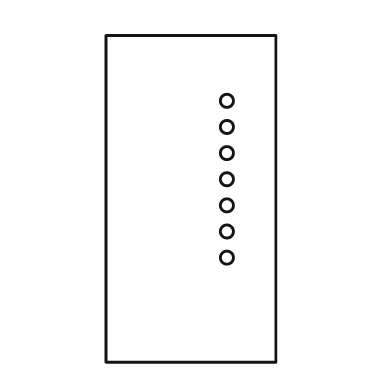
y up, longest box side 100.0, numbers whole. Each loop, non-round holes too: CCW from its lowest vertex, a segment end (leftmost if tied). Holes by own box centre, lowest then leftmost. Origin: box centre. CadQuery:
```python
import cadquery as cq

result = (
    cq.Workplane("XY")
    .moveTo(-26.0, -50.0)
    .lineTo(26.0, -50.0)
    .lineTo(26.0, 50.0)
    .lineTo(-26.0, 50.0)
    .close()
    .moveTo(11.0, -18.0)
    .circle(2.0)
    .moveTo(11.0, -10.0)
    .circle(2.0)
    .moveTo(11.0, -2.0)
    .circle(2.0)
    .moveTo(11.0, 6.0)
    .circle(2.0)
    .moveTo(11.0, 14.0)
    .circle(2.0)
    .moveTo(11.0, 22.0)
    .circle(2.0)
    .moveTo(11.0, 30.0)
    .circle(2.0)
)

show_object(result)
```